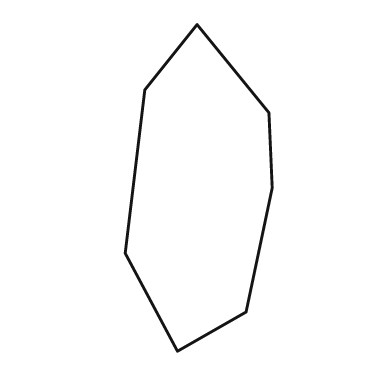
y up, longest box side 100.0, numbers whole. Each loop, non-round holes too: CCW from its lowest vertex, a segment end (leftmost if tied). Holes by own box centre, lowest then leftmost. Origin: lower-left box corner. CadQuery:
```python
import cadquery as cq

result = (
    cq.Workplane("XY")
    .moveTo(16.0, 0.0)
    .lineTo(37.0, 12.0)
    .lineTo(45.0, 50.0)
    .lineTo(44.0, 73.0)
    .lineTo(22.0, 100.0)
    .lineTo(6.0, 80.0)
    .lineTo(0.0, 30.0)
    .close()
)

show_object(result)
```